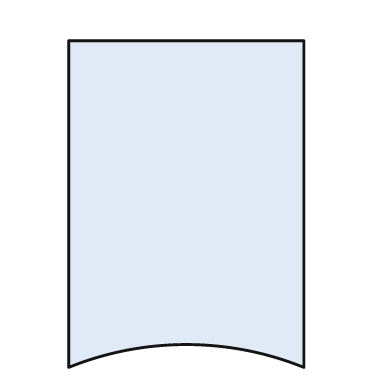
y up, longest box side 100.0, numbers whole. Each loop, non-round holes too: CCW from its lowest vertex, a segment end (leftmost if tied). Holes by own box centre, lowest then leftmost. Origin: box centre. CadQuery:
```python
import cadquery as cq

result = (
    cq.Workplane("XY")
    .moveTo(-36.0, -50.0)
    .threePointArc((0.0, -43.0), (36.0, -50.0))
    .lineTo(36.0, 50.0)
    .lineTo(-36.0, 50.0)
    .close()
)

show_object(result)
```